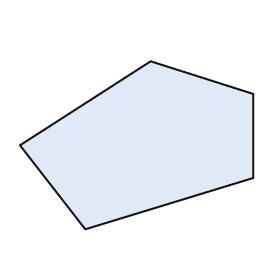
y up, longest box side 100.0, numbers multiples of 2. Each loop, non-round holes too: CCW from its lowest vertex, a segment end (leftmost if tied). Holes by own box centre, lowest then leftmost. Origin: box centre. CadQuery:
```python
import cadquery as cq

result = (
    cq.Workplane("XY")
    .moveTo(-22.0, -36.0)
    .lineTo(50.0, -14.0)
    .lineTo(50.0, 22.0)
    .lineTo(6.0, 36.0)
    .lineTo(-50.0, 0.0)
    .close()
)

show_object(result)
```